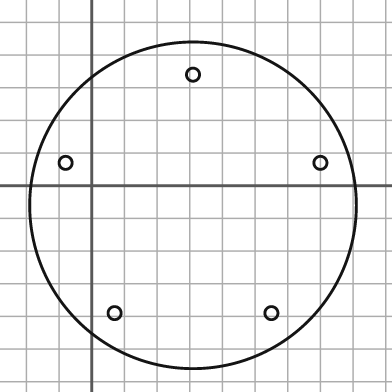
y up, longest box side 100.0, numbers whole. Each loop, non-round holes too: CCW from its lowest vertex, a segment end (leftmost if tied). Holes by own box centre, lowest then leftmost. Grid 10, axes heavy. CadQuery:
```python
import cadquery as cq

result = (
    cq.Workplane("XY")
    .moveTo(31.0, -6.0)
    .circle(50.0)
    .moveTo(7.0, -39.0)
    .circle(2.0)
    .moveTo(55.0, -39.0)
    .circle(2.0)
    .moveTo(-8.0, 7.0)
    .circle(2.0)
    .moveTo(70.0, 7.0)
    .circle(2.0)
    .moveTo(31.0, 34.0)
    .circle(2.0)
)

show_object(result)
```